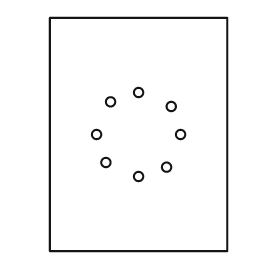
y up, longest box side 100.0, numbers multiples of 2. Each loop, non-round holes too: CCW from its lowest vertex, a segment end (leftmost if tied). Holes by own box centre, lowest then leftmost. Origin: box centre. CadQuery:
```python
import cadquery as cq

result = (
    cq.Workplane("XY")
    .moveTo(-38.0, -50.0)
    .lineTo(38.0, -50.0)
    .lineTo(38.0, 50.0)
    .lineTo(-38.0, 50.0)
    .close()
    .moveTo(0.0, -18.0)
    .circle(2.0)
    .moveTo(12.0, -14.0)
    .circle(2.0)
    .moveTo(-14.0, -12.0)
    .circle(2.0)
    .moveTo(-18.0, 0.0)
    .circle(2.0)
    .moveTo(18.0, 0.0)
    .circle(2.0)
    .moveTo(14.0, 12.0)
    .circle(2.0)
    .moveTo(-12.0, 14.0)
    .circle(2.0)
    .moveTo(0.0, 18.0)
    .circle(2.0)
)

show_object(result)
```